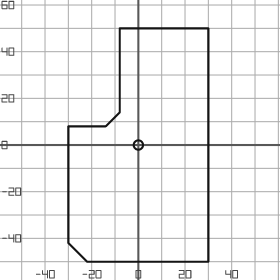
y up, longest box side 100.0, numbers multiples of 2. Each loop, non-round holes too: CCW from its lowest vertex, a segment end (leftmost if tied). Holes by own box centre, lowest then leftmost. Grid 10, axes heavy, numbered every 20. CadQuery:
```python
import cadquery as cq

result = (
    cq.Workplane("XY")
    .moveTo(-22.0, -50.0)
    .lineTo(30.0, -50.0)
    .lineTo(30.0, 50.0)
    .lineTo(-8.0, 50.0)
    .lineTo(-8.0, 14.0)
    .lineTo(-14.0, 8.0)
    .lineTo(-30.0, 8.0)
    .lineTo(-30.0, -42.0)
    .close()
    .moveTo(0.0, 0.0)
    .circle(2.0)
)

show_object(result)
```